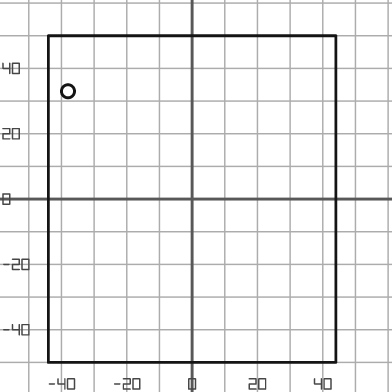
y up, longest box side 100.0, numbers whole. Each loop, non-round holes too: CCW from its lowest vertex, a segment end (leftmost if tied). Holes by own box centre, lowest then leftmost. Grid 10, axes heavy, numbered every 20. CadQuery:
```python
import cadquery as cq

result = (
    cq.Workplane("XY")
    .moveTo(-44.0, -50.0)
    .lineTo(44.0, -50.0)
    .lineTo(44.0, 50.0)
    .lineTo(-44.0, 50.0)
    .close()
    .moveTo(-38.0, 33.0)
    .circle(2.0)
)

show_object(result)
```